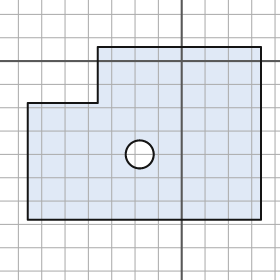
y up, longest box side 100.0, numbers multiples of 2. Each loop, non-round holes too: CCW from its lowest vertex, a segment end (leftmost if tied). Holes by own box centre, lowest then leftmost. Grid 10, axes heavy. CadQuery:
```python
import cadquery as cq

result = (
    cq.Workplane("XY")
    .moveTo(-66.0, -68.0)
    .lineTo(34.0, -68.0)
    .lineTo(34.0, 6.0)
    .lineTo(-36.0, 6.0)
    .lineTo(-36.0, -18.0)
    .lineTo(-66.0, -18.0)
    .close()
    .moveTo(-18.0, -40.0)
    .circle(6.0)
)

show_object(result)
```